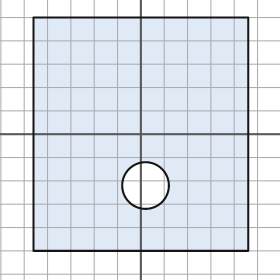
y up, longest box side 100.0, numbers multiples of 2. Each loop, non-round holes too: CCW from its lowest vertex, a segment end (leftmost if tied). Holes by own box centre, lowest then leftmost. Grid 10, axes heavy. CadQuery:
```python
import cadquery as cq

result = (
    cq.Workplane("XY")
    .moveTo(-46.0, -50.0)
    .lineTo(46.0, -50.0)
    .lineTo(46.0, 50.0)
    .lineTo(-46.0, 50.0)
    .close()
    .moveTo(2.0, -22.0)
    .circle(10.0)
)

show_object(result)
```